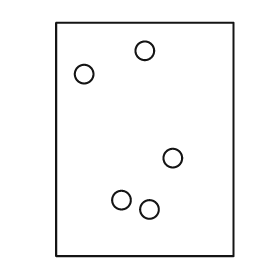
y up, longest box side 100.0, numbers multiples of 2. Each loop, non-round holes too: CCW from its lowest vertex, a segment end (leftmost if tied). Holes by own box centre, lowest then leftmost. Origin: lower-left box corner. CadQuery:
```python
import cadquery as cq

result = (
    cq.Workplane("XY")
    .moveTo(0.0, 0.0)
    .lineTo(76.0, 0.0)
    .lineTo(76.0, 100.0)
    .lineTo(0.0, 100.0)
    .close()
    .moveTo(40.0, 20.0)
    .circle(4.0)
    .moveTo(28.0, 24.0)
    .circle(4.0)
    .moveTo(50.0, 42.0)
    .circle(4.0)
    .moveTo(12.0, 78.0)
    .circle(4.0)
    .moveTo(38.0, 88.0)
    .circle(4.0)
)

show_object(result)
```